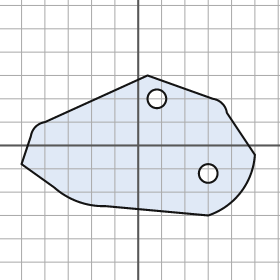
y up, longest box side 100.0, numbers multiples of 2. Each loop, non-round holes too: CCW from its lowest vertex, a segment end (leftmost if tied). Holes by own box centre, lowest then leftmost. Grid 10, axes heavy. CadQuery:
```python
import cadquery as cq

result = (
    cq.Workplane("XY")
    .moveTo(30.0, -30.0)
    .threePointArc((44.0, -20.0), (50.0, -4.0))
    .lineTo(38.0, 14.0)
    .threePointArc((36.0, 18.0), (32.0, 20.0))
    .lineTo(4.0, 30.0)
    .lineTo(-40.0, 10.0)
    .threePointArc((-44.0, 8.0), (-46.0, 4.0))
    .lineTo(-50.0, -8.0)
    .lineTo(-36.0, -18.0)
    .threePointArc((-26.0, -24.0), (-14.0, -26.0))
    .close()
    .moveTo(30.0, -12.0)
    .circle(4.0)
    .moveTo(8.0, 20.0)
    .circle(4.0)
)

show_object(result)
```